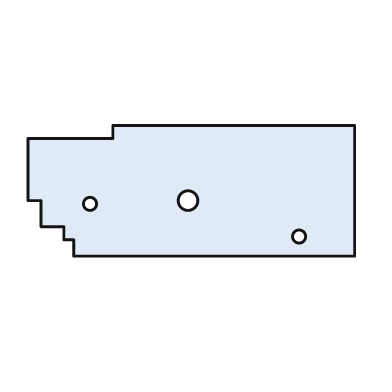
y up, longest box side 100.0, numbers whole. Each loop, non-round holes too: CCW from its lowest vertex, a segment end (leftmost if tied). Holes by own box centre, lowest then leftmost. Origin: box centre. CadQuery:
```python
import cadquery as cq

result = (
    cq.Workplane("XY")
    .moveTo(-36.0, -20.0)
    .lineTo(50.0, -20.0)
    .lineTo(50.0, 20.0)
    .lineTo(-24.0, 20.0)
    .lineTo(-24.0, 16.0)
    .lineTo(-50.0, 16.0)
    .lineTo(-50.0, -3.0)
    .lineTo(-46.0, -3.0)
    .lineTo(-46.0, -11.0)
    .lineTo(-39.0, -11.0)
    .lineTo(-39.0, -15.0)
    .lineTo(-36.0, -15.0)
    .close()
    .moveTo(33.0, -14.0)
    .circle(2.0)
    .moveTo(-31.0, -4.0)
    .circle(2.0)
    .moveTo(-1.0, -3.0)
    .circle(3.0)
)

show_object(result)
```